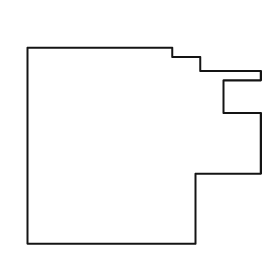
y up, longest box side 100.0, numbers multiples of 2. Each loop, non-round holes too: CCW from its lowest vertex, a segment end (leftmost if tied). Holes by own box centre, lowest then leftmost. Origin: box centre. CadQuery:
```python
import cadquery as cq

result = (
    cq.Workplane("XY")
    .moveTo(-50.0, -42.0)
    .lineTo(22.0, -42.0)
    .lineTo(22.0, -12.0)
    .lineTo(50.0, -12.0)
    .lineTo(50.0, 14.0)
    .lineTo(34.0, 14.0)
    .lineTo(34.0, 28.0)
    .lineTo(50.0, 28.0)
    .lineTo(50.0, 32.0)
    .lineTo(24.0, 32.0)
    .lineTo(24.0, 38.0)
    .lineTo(12.0, 38.0)
    .lineTo(12.0, 42.0)
    .lineTo(-50.0, 42.0)
    .close()
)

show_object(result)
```